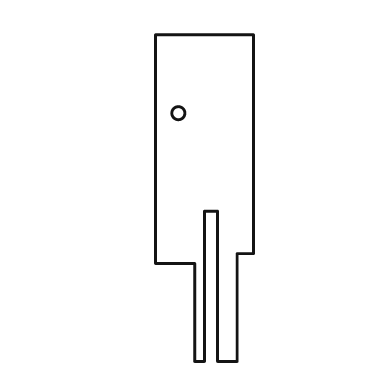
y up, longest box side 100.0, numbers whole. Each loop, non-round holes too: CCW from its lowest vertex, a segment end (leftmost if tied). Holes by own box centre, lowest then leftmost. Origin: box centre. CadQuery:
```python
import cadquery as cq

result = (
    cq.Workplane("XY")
    .moveTo(-3.0, -50.0)
    .lineTo(0.0, -50.0)
    .lineTo(0.0, -4.0)
    .lineTo(4.0, -4.0)
    .lineTo(4.0, -50.0)
    .lineTo(10.0, -50.0)
    .lineTo(10.0, -17.0)
    .lineTo(15.0, -17.0)
    .lineTo(15.0, 50.0)
    .lineTo(-15.0, 50.0)
    .lineTo(-15.0, -20.0)
    .lineTo(-3.0, -20.0)
    .close()
    .moveTo(-8.0, 26.0)
    .circle(2.0)
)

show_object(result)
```